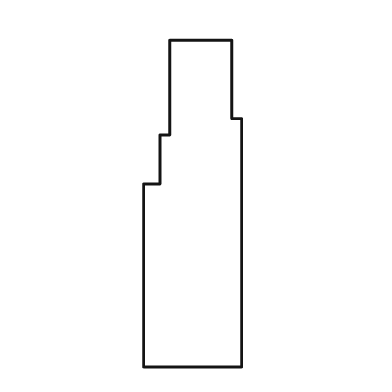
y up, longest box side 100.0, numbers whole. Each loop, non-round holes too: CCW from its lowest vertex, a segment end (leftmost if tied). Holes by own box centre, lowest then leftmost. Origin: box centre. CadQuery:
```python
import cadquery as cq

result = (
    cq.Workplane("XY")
    .moveTo(-15.0, -50.0)
    .lineTo(15.0, -50.0)
    .lineTo(15.0, 26.0)
    .lineTo(12.0, 26.0)
    .lineTo(12.0, 50.0)
    .lineTo(-7.0, 50.0)
    .lineTo(-7.0, 21.0)
    .lineTo(-10.0, 21.0)
    .lineTo(-10.0, 6.0)
    .lineTo(-15.0, 6.0)
    .close()
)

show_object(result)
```